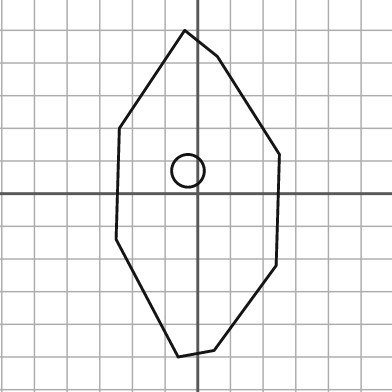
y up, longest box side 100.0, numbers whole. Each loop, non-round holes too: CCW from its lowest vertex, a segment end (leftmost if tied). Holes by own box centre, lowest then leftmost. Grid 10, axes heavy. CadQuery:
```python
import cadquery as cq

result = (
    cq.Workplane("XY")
    .moveTo(-6.0, -50.0)
    .lineTo(5.0, -48.0)
    .lineTo(24.0, -22.0)
    .lineTo(25.0, 12.0)
    .lineTo(6.0, 42.0)
    .lineTo(-4.0, 50.0)
    .lineTo(-24.0, 20.0)
    .lineTo(-25.0, -14.0)
    .close()
    .moveTo(-3.0, 7.0)
    .circle(5.0)
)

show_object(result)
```